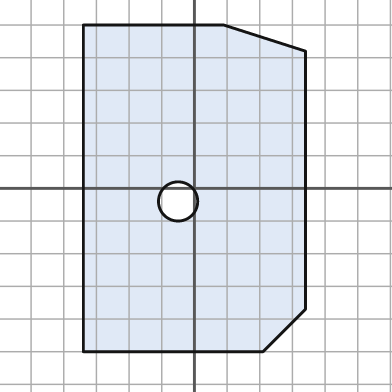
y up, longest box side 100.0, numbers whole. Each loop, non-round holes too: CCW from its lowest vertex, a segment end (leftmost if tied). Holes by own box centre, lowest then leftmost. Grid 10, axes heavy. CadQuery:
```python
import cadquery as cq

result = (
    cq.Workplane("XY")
    .moveTo(-34.0, -50.0)
    .lineTo(21.0, -50.0)
    .lineTo(34.0, -37.0)
    .lineTo(34.0, 42.0)
    .lineTo(9.0, 50.0)
    .lineTo(-34.0, 50.0)
    .close()
    .moveTo(-5.0, -4.0)
    .circle(6.0)
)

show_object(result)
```